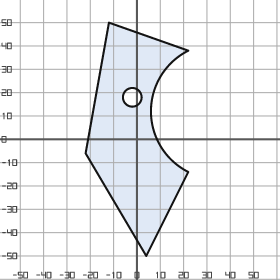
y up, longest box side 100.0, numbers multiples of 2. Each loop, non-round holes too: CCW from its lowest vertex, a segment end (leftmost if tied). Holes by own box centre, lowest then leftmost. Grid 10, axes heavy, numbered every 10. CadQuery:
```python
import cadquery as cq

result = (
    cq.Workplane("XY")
    .moveTo(4.0, -50.0)
    .lineTo(22.0, -14.0)
    .threePointArc((6.0, 12.0), (22.0, 38.0))
    .lineTo(-12.0, 50.0)
    .lineTo(-22.0, -6.0)
    .close()
    .moveTo(-2.0, 18.0)
    .circle(4.0)
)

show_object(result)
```